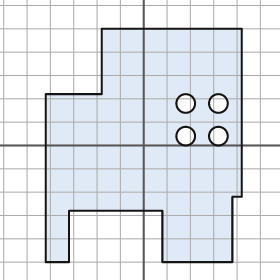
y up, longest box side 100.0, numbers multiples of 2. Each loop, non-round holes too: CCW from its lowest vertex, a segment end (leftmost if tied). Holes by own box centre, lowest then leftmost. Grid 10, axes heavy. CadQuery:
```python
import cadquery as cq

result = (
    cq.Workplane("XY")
    .moveTo(-42.0, -50.0)
    .lineTo(-32.0, -50.0)
    .lineTo(-32.0, -28.0)
    .lineTo(8.0, -28.0)
    .lineTo(8.0, -50.0)
    .lineTo(38.0, -50.0)
    .lineTo(38.0, -22.0)
    .lineTo(42.0, -22.0)
    .lineTo(42.0, 50.0)
    .lineTo(-18.0, 50.0)
    .lineTo(-18.0, 22.0)
    .lineTo(-42.0, 22.0)
    .close()
    .moveTo(18.0, 4.0)
    .circle(4.0)
    .moveTo(32.0, 4.0)
    .circle(4.0)
    .moveTo(18.0, 18.0)
    .circle(4.0)
    .moveTo(32.0, 18.0)
    .circle(4.0)
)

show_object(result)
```